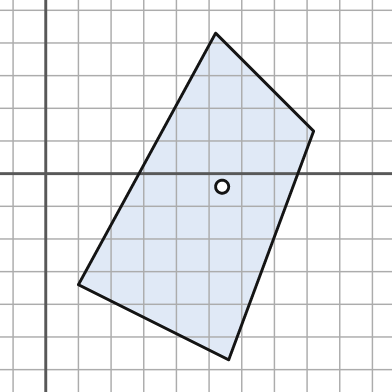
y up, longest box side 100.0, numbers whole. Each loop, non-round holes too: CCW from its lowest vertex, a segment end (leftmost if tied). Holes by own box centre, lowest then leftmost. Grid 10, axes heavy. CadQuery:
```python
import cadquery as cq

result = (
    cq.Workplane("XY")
    .moveTo(56.0, -57.0)
    .lineTo(82.0, 13.0)
    .lineTo(52.0, 43.0)
    .lineTo(10.0, -34.0)
    .close()
    .moveTo(54.0, -4.0)
    .circle(2.0)
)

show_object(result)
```